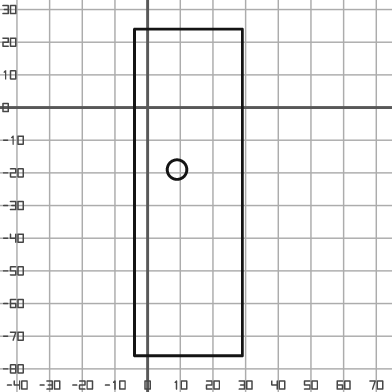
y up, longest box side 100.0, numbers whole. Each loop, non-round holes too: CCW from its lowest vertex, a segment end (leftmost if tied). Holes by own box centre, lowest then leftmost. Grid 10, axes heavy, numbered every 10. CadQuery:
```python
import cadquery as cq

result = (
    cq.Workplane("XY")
    .moveTo(-4.0, -76.0)
    .lineTo(29.0, -76.0)
    .lineTo(29.0, 24.0)
    .lineTo(-4.0, 24.0)
    .close()
    .moveTo(9.0, -19.0)
    .circle(3.0)
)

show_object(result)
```